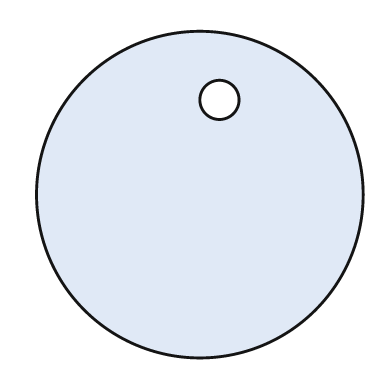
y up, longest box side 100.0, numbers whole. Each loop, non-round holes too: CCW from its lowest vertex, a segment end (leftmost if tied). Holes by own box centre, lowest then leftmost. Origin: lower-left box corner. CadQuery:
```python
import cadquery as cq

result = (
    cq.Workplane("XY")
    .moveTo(50.0, 50.0)
    .circle(50.0)
    .moveTo(56.0, 79.0)
    .circle(6.0)
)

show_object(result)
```